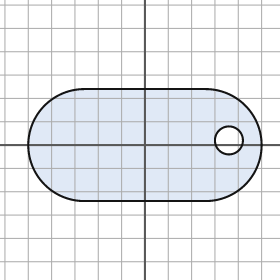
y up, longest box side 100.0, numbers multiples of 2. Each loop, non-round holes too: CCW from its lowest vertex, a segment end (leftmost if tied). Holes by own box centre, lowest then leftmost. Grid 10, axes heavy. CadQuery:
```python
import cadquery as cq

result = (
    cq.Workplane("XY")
    .moveTo(-26.0, -24.0)
    .lineTo(26.0, -24.0)
    .threePointArc((50.0, 0.0), (26.0, 24.0))
    .lineTo(-26.0, 24.0)
    .threePointArc((-50.0, 0.0), (-26.0, -24.0))
    .close()
    .moveTo(36.0, 2.0)
    .circle(6.0)
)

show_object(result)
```